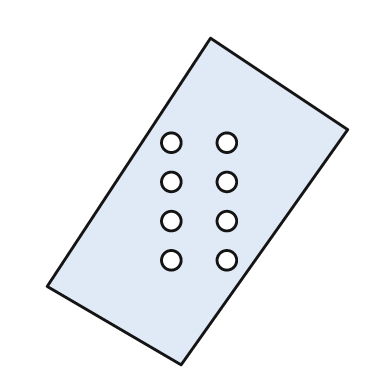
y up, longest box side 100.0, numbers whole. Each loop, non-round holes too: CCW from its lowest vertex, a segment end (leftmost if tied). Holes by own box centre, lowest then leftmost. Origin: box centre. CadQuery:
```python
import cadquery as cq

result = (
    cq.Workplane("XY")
    .moveTo(-5.0, -50.0)
    .lineTo(46.0, 22.0)
    .lineTo(4.0, 50.0)
    .lineTo(-46.0, -26.0)
    .close()
    .moveTo(-8.0, -18.0)
    .circle(3.0)
    .moveTo(9.0, -18.0)
    .circle(3.0)
    .moveTo(-8.0, -6.0)
    .circle(3.0)
    .moveTo(9.0, -6.0)
    .circle(3.0)
    .moveTo(-8.0, 6.0)
    .circle(3.0)
    .moveTo(9.0, 6.0)
    .circle(3.0)
    .moveTo(-8.0, 18.0)
    .circle(3.0)
    .moveTo(9.0, 18.0)
    .circle(3.0)
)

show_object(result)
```